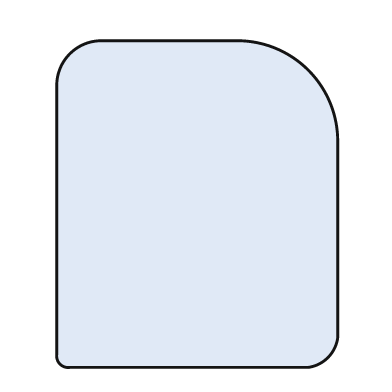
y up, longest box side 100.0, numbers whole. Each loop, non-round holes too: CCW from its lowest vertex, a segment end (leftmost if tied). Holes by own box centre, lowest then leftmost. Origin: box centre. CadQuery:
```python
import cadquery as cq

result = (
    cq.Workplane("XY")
    .moveTo(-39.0, -50.0)
    .lineTo(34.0, -50.0)
    .threePointArc((40.0, -47.0), (43.0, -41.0))
    .lineTo(43.0, 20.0)
    .threePointArc((34.0, 41.0), (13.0, 50.0))
    .lineTo(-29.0, 50.0)
    .threePointArc((-39.0, 46.0), (-43.0, 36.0))
    .lineTo(-43.0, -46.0)
    .threePointArc((-42.0, -49.0), (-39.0, -50.0))
    .close()
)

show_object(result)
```